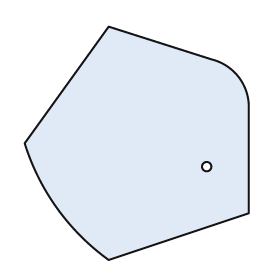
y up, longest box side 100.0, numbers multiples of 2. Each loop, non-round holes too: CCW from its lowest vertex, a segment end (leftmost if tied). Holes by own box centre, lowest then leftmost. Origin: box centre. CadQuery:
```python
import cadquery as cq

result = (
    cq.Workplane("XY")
    .moveTo(-12.0, -50.0)
    .lineTo(48.0, -30.0)
    .lineTo(48.0, 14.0)
    .threePointArc((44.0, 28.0), (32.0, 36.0))
    .lineTo(-12.0, 50.0)
    .lineTo(-48.0, 0.0)
    .threePointArc((-34.0, -28.0), (-12.0, -50.0))
    .close()
    .moveTo(30.0, -10.0)
    .circle(2.0)
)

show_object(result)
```